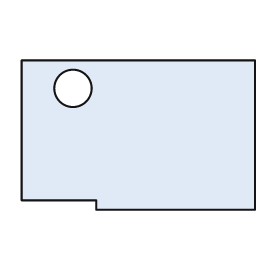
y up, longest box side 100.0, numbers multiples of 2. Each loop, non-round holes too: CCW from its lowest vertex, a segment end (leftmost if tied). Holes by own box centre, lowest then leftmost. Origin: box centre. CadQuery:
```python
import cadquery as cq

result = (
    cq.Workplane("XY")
    .moveTo(-18.0, -32.0)
    .lineTo(50.0, -32.0)
    .lineTo(50.0, 32.0)
    .lineTo(-50.0, 32.0)
    .lineTo(-50.0, -28.0)
    .lineTo(-18.0, -28.0)
    .close()
    .moveTo(-28.0, 20.0)
    .circle(8.0)
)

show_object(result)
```